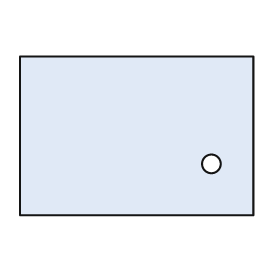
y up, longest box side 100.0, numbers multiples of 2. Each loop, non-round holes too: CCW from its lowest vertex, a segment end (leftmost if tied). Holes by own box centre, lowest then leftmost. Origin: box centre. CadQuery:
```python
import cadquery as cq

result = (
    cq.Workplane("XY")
    .moveTo(-50.0, -34.0)
    .lineTo(50.0, -34.0)
    .lineTo(50.0, 34.0)
    .lineTo(-50.0, 34.0)
    .close()
    .moveTo(32.0, -12.0)
    .circle(4.0)
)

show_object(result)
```